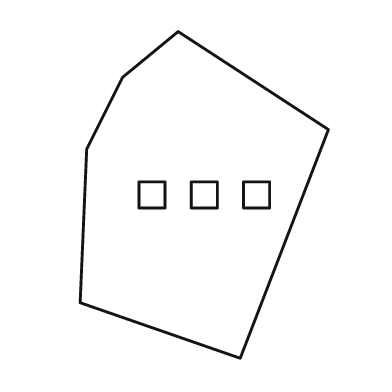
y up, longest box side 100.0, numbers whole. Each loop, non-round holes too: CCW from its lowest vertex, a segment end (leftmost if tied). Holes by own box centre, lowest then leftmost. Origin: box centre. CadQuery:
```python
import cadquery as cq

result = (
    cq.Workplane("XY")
    .moveTo(11.0, -50.0)
    .lineTo(38.0, 20.0)
    .lineTo(-8.0, 50.0)
    .lineTo(-25.0, 36.0)
    .lineTo(-36.0, 14.0)
    .lineTo(-38.0, -33.0)
    .close()
    .moveTo(-20.0, -4.0)
    .lineTo(-12.0, -4.0)
    .lineTo(-12.0, 4.0)
    .lineTo(-20.0, 4.0)
    .close()
    .moveTo(-4.0, -4.0)
    .lineTo(4.0, -4.0)
    .lineTo(4.0, 4.0)
    .lineTo(-4.0, 4.0)
    .close()
    .moveTo(12.0, -4.0)
    .lineTo(20.0, -4.0)
    .lineTo(20.0, 4.0)
    .lineTo(12.0, 4.0)
    .close()
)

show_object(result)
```